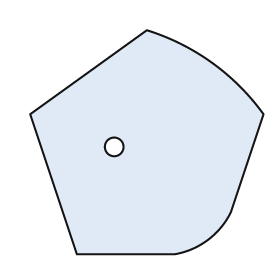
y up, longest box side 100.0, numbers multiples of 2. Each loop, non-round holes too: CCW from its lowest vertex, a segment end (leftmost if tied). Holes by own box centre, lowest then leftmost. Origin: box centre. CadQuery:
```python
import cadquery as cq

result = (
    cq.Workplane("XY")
    .moveTo(-30.0, -48.0)
    .lineTo(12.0, -48.0)
    .threePointArc((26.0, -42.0), (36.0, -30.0))
    .lineTo(50.0, 12.0)
    .threePointArc((28.0, 34.0), (0.0, 48.0))
    .lineTo(-50.0, 12.0)
    .close()
    .moveTo(-14.0, -2.0)
    .circle(4.0)
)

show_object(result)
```